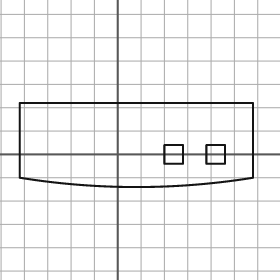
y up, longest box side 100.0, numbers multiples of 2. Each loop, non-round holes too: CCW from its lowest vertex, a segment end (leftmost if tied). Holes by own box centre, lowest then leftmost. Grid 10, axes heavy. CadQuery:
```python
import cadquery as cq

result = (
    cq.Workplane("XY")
    .moveTo(-42.0, -10.0)
    .threePointArc((8.0, -14.0), (58.0, -10.0))
    .lineTo(58.0, 22.0)
    .lineTo(-42.0, 22.0)
    .close()
    .moveTo(20.0, -4.0)
    .lineTo(28.0, -4.0)
    .lineTo(28.0, 4.0)
    .lineTo(20.0, 4.0)
    .close()
    .moveTo(38.0, -4.0)
    .lineTo(46.0, -4.0)
    .lineTo(46.0, 4.0)
    .lineTo(38.0, 4.0)
    .close()
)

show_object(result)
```